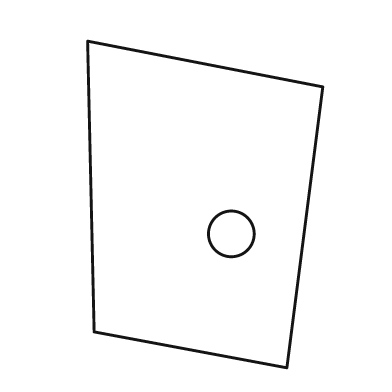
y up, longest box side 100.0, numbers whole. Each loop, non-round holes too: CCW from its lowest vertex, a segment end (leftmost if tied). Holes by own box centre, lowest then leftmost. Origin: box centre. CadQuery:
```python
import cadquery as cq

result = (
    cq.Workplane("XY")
    .moveTo(25.0, -50.0)
    .lineTo(36.0, 36.0)
    .lineTo(-36.0, 50.0)
    .lineTo(-34.0, -39.0)
    .close()
    .moveTo(8.0, -9.0)
    .circle(7.0)
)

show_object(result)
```